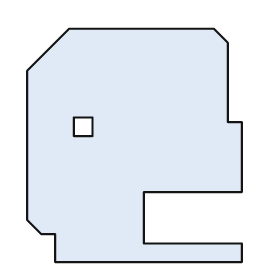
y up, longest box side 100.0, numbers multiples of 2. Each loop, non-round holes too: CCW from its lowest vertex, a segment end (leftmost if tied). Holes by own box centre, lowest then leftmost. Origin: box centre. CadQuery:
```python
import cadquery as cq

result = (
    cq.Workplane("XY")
    .moveTo(-34.0, -50.0)
    .lineTo(46.0, -50.0)
    .lineTo(46.0, -42.0)
    .lineTo(4.0, -42.0)
    .lineTo(4.0, -20.0)
    .lineTo(46.0, -20.0)
    .lineTo(46.0, 10.0)
    .lineTo(40.0, 10.0)
    .lineTo(40.0, 44.0)
    .lineTo(34.0, 50.0)
    .lineTo(-28.0, 50.0)
    .lineTo(-46.0, 32.0)
    .lineTo(-46.0, -32.0)
    .lineTo(-40.0, -38.0)
    .lineTo(-34.0, -38.0)
    .close()
    .moveTo(-26.0, 4.0)
    .lineTo(-18.0, 4.0)
    .lineTo(-18.0, 12.0)
    .lineTo(-26.0, 12.0)
    .close()
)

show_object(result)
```